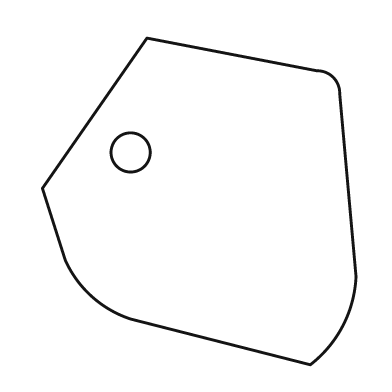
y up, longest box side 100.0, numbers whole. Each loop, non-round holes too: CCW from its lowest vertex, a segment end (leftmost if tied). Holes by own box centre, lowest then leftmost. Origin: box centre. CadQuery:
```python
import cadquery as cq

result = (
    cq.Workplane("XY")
    .moveTo(34.0, -50.0)
    .threePointArc((44.0, -38.0), (48.0, -23.0))
    .lineTo(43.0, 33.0)
    .threePointArc((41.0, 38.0), (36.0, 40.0))
    .lineTo(-16.0, 50.0)
    .lineTo(-48.0, 4.0)
    .lineTo(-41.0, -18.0)
    .threePointArc((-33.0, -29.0), (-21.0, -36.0))
    .close()
    .moveTo(-21.0, 15.0)
    .circle(6.0)
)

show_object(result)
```